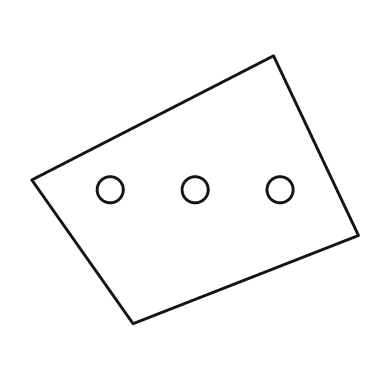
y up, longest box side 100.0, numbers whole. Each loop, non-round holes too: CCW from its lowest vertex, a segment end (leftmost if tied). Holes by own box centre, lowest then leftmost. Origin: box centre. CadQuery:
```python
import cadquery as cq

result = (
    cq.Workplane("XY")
    .moveTo(-19.0, -41.0)
    .lineTo(50.0, -14.0)
    .lineTo(24.0, 41.0)
    .lineTo(-50.0, 3.0)
    .close()
    .moveTo(-26.0, 0.0)
    .circle(4.0)
    .moveTo(0.0, 0.0)
    .circle(4.0)
    .moveTo(26.0, 0.0)
    .circle(4.0)
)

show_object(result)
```